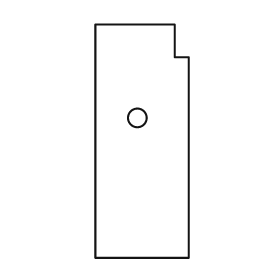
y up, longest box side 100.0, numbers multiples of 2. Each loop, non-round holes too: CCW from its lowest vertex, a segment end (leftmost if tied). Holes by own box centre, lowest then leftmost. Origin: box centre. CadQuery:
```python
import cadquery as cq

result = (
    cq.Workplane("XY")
    .moveTo(-20.0, -50.0)
    .lineTo(20.0, -50.0)
    .lineTo(20.0, 36.0)
    .lineTo(14.0, 36.0)
    .lineTo(14.0, 50.0)
    .lineTo(-20.0, 50.0)
    .close()
    .moveTo(-2.0, 10.0)
    .circle(4.0)
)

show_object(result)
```